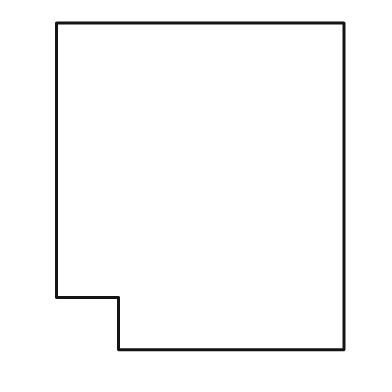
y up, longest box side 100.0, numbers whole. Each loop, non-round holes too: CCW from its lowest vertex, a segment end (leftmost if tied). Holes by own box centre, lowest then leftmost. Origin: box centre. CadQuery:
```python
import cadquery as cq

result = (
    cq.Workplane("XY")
    .moveTo(-25.0, -50.0)
    .lineTo(44.0, -50.0)
    .lineTo(44.0, 50.0)
    .lineTo(-44.0, 50.0)
    .lineTo(-44.0, -34.0)
    .lineTo(-25.0, -34.0)
    .close()
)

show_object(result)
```